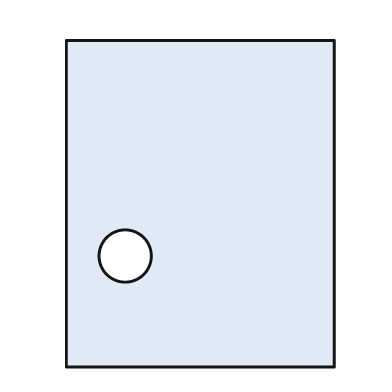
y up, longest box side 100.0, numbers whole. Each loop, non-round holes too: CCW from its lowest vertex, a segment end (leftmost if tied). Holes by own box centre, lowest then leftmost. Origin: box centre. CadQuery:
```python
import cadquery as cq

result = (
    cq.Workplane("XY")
    .moveTo(-41.0, -50.0)
    .lineTo(41.0, -50.0)
    .lineTo(41.0, 50.0)
    .lineTo(-41.0, 50.0)
    .close()
    .moveTo(-23.0, -16.0)
    .circle(8.0)
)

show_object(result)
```